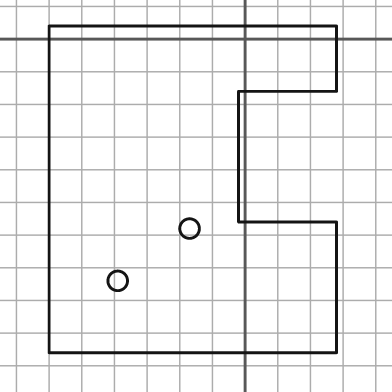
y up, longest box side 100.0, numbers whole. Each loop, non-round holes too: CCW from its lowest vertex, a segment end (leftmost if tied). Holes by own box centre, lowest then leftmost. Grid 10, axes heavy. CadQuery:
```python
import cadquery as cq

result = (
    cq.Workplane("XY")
    .moveTo(-60.0, -96.0)
    .lineTo(28.0, -96.0)
    .lineTo(28.0, -56.0)
    .lineTo(-2.0, -56.0)
    .lineTo(-2.0, -16.0)
    .lineTo(28.0, -16.0)
    .lineTo(28.0, 4.0)
    .lineTo(-60.0, 4.0)
    .close()
    .moveTo(-39.0, -74.0)
    .circle(3.0)
    .moveTo(-17.0, -58.0)
    .circle(3.0)
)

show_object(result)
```